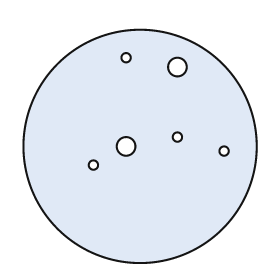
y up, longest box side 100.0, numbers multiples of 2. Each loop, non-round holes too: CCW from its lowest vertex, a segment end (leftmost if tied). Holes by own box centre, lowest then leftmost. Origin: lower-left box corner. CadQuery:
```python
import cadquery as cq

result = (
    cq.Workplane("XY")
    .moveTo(50.0, 50.0)
    .circle(50.0)
    .moveTo(30.0, 42.0)
    .circle(2.0)
    .moveTo(86.0, 48.0)
    .circle(2.0)
    .moveTo(44.0, 50.0)
    .circle(4.0)
    .moveTo(66.0, 54.0)
    .circle(2.0)
    .moveTo(66.0, 84.0)
    .circle(4.0)
    .moveTo(44.0, 88.0)
    .circle(2.0)
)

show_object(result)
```